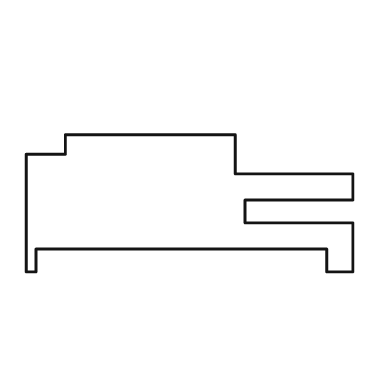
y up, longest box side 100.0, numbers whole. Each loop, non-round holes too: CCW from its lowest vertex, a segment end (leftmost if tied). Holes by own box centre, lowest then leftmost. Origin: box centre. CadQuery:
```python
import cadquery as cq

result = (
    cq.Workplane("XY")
    .moveTo(-50.0, -21.0)
    .lineTo(-47.0, -21.0)
    .lineTo(-47.0, -14.0)
    .lineTo(42.0, -14.0)
    .lineTo(42.0, -21.0)
    .lineTo(50.0, -21.0)
    .lineTo(50.0, -6.0)
    .lineTo(17.0, -6.0)
    .lineTo(17.0, 1.0)
    .lineTo(50.0, 1.0)
    .lineTo(50.0, 9.0)
    .lineTo(14.0, 9.0)
    .lineTo(14.0, 21.0)
    .lineTo(-38.0, 21.0)
    .lineTo(-38.0, 15.0)
    .lineTo(-50.0, 15.0)
    .close()
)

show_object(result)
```